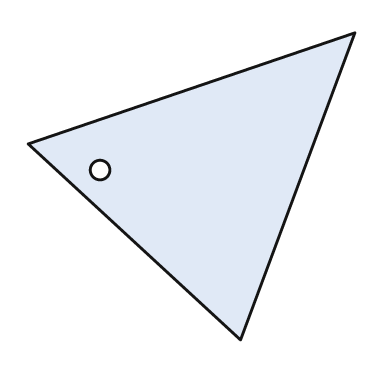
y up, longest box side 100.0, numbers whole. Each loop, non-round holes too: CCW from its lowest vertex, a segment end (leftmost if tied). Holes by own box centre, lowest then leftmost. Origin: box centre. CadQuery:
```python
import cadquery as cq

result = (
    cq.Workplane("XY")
    .moveTo(15.0, -47.0)
    .lineTo(50.0, 47.0)
    .lineTo(-50.0, 13.0)
    .close()
    .moveTo(-28.0, 5.0)
    .circle(3.0)
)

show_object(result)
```